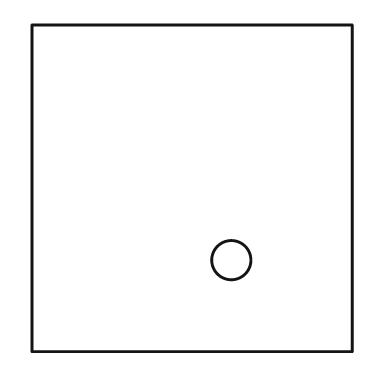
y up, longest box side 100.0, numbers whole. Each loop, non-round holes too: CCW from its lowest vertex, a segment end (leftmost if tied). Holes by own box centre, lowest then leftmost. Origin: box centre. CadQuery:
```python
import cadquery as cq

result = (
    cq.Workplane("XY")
    .moveTo(-49.0, -50.0)
    .lineTo(49.0, -50.0)
    .lineTo(49.0, 50.0)
    .lineTo(-49.0, 50.0)
    .close()
    .moveTo(12.0, -22.0)
    .circle(6.0)
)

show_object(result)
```